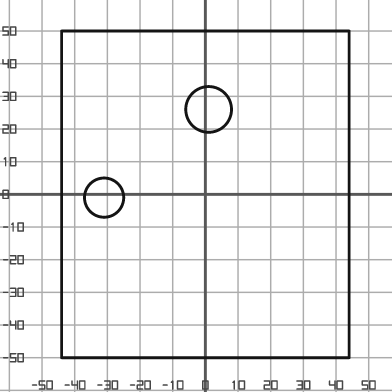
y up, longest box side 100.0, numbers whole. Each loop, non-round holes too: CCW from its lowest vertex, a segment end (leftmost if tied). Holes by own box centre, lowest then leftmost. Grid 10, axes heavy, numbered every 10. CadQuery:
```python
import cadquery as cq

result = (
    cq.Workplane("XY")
    .moveTo(-44.0, -50.0)
    .lineTo(44.0, -50.0)
    .lineTo(44.0, 50.0)
    .lineTo(-44.0, 50.0)
    .close()
    .moveTo(-31.0, -1.0)
    .circle(6.0)
    .moveTo(1.0, 26.0)
    .circle(7.0)
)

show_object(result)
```